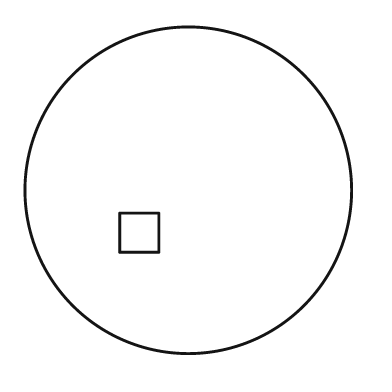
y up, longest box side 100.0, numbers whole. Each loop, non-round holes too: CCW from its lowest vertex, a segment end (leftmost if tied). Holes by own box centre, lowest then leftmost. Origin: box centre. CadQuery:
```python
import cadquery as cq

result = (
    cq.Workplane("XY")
    .moveTo(0.0, 0.0)
    .circle(50.0)
    .moveTo(-21.0, -19.0)
    .lineTo(-9.0, -19.0)
    .lineTo(-9.0, -7.0)
    .lineTo(-21.0, -7.0)
    .close()
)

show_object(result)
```